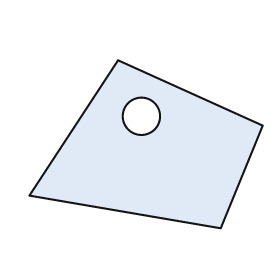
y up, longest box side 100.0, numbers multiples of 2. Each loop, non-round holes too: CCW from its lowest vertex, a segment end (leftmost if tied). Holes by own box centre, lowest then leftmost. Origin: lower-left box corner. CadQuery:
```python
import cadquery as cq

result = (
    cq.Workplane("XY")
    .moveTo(82.0, 0.0)
    .lineTo(100.0, 44.0)
    .lineTo(38.0, 72.0)
    .lineTo(0.0, 14.0)
    .close()
    .moveTo(48.0, 48.0)
    .circle(8.0)
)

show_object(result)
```